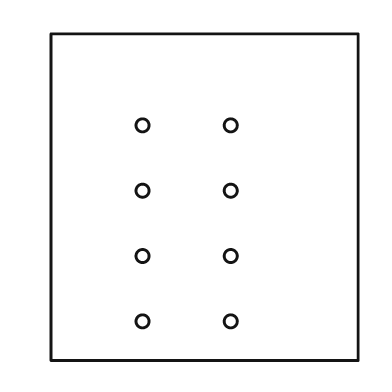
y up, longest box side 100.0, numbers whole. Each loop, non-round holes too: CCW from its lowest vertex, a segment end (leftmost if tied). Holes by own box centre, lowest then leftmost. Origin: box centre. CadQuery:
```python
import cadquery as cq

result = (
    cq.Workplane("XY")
    .moveTo(-47.0, -50.0)
    .lineTo(47.0, -50.0)
    .lineTo(47.0, 50.0)
    .lineTo(-47.0, 50.0)
    .close()
    .moveTo(-19.0, -38.0)
    .circle(2.0)
    .moveTo(8.0, -38.0)
    .circle(2.0)
    .moveTo(-19.0, -18.0)
    .circle(2.0)
    .moveTo(8.0, -18.0)
    .circle(2.0)
    .moveTo(-19.0, 2.0)
    .circle(2.0)
    .moveTo(8.0, 2.0)
    .circle(2.0)
    .moveTo(-19.0, 22.0)
    .circle(2.0)
    .moveTo(8.0, 22.0)
    .circle(2.0)
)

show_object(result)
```